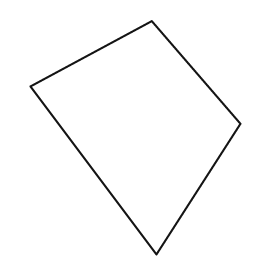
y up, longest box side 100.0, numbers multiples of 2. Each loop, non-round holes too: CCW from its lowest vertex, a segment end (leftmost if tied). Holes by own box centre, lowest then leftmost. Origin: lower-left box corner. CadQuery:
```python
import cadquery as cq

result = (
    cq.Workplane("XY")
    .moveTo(54.0, 0.0)
    .lineTo(90.0, 56.0)
    .lineTo(52.0, 100.0)
    .lineTo(0.0, 72.0)
    .close()
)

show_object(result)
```